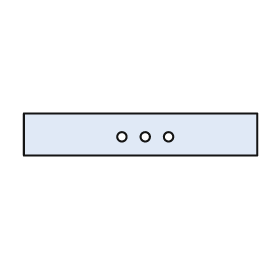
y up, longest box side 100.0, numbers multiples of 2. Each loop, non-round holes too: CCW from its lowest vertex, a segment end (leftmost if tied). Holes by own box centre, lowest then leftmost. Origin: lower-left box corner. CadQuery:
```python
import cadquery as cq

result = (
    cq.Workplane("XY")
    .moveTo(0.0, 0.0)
    .lineTo(100.0, 0.0)
    .lineTo(100.0, 18.0)
    .lineTo(0.0, 18.0)
    .close()
    .moveTo(42.0, 8.0)
    .circle(2.0)
    .moveTo(52.0, 8.0)
    .circle(2.0)
    .moveTo(62.0, 8.0)
    .circle(2.0)
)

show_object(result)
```